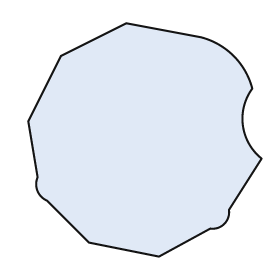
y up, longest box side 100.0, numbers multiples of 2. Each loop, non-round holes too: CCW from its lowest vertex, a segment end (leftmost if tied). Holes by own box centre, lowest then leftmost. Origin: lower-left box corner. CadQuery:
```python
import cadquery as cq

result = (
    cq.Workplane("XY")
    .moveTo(56.0, 0.0)
    .lineTo(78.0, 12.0)
    .threePointArc((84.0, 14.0), (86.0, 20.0))
    .lineTo(100.0, 42.0)
    .threePointArc((92.0, 56.0), (96.0, 72.0))
    .threePointArc((88.0, 86.0), (74.0, 94.0))
    .lineTo(42.0, 100.0)
    .lineTo(14.0, 86.0)
    .lineTo(0.0, 58.0)
    .lineTo(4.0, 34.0)
    .threePointArc((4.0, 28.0), (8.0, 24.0))
    .lineTo(26.0, 6.0)
    .close()
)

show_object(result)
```